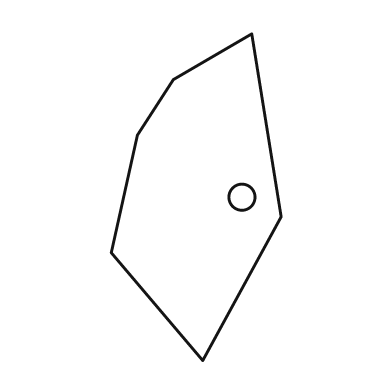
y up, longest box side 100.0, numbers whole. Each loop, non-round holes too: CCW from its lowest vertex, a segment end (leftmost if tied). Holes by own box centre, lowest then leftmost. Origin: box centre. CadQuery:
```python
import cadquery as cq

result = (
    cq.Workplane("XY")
    .moveTo(2.0, -50.0)
    .lineTo(26.0, -6.0)
    .lineTo(17.0, 50.0)
    .lineTo(-7.0, 36.0)
    .lineTo(-18.0, 19.0)
    .lineTo(-26.0, -17.0)
    .close()
    .moveTo(14.0, 0.0)
    .circle(4.0)
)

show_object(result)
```